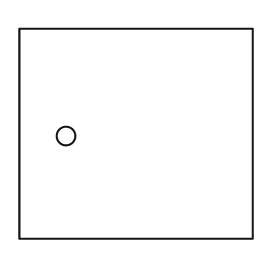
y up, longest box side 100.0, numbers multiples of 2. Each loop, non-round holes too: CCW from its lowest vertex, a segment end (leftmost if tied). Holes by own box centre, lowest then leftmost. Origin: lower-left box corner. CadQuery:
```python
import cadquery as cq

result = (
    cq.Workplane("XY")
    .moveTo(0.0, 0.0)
    .lineTo(100.0, 0.0)
    .lineTo(100.0, 90.0)
    .lineTo(0.0, 90.0)
    .close()
    .moveTo(20.0, 44.0)
    .circle(4.0)
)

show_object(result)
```